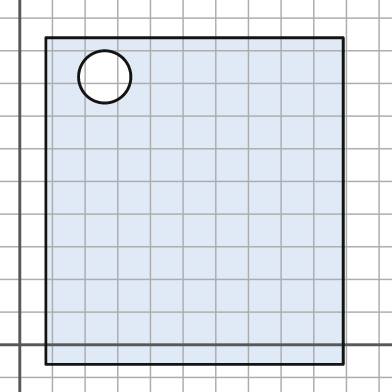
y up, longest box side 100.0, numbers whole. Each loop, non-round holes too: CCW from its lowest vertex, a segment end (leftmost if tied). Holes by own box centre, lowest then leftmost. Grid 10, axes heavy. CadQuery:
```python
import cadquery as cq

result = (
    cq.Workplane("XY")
    .moveTo(8.0, -6.0)
    .lineTo(99.0, -6.0)
    .lineTo(99.0, 94.0)
    .lineTo(8.0, 94.0)
    .close()
    .moveTo(26.0, 82.0)
    .circle(8.0)
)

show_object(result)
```